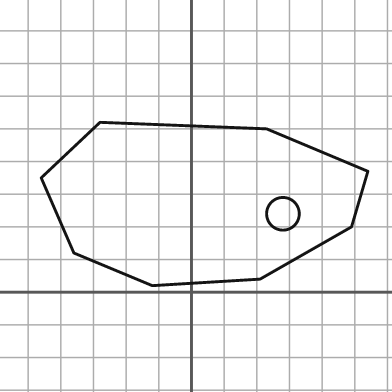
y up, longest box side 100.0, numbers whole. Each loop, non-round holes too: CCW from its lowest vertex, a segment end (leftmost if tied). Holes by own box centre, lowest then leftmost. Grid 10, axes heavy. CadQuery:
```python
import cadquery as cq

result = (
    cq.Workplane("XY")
    .moveTo(-12.0, 2.0)
    .lineTo(21.0, 4.0)
    .lineTo(49.0, 20.0)
    .lineTo(54.0, 37.0)
    .lineTo(23.0, 50.0)
    .lineTo(-28.0, 52.0)
    .lineTo(-46.0, 35.0)
    .lineTo(-36.0, 12.0)
    .close()
    .moveTo(28.0, 24.0)
    .circle(5.0)
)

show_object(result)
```